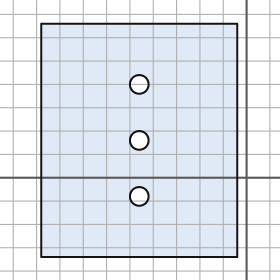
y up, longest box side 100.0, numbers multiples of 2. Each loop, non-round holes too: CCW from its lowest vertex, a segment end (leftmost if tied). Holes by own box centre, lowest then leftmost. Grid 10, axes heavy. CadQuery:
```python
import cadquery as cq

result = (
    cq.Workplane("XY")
    .moveTo(-88.0, -34.0)
    .lineTo(-4.0, -34.0)
    .lineTo(-4.0, 66.0)
    .lineTo(-88.0, 66.0)
    .close()
    .moveTo(-46.0, -8.0)
    .circle(4.0)
    .moveTo(-46.0, 16.0)
    .circle(4.0)
    .moveTo(-46.0, 40.0)
    .circle(4.0)
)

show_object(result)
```